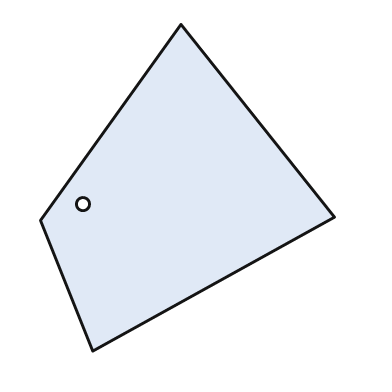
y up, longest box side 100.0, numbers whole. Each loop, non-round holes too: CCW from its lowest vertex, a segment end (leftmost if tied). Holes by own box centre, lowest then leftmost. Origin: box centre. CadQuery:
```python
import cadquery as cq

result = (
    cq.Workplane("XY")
    .moveTo(-29.0, -50.0)
    .lineTo(45.0, -9.0)
    .lineTo(-2.0, 50.0)
    .lineTo(-45.0, -10.0)
    .close()
    .moveTo(-32.0, -5.0)
    .circle(2.0)
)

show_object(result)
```